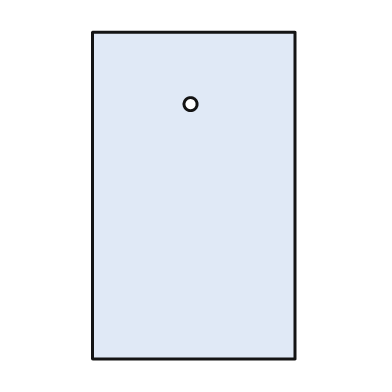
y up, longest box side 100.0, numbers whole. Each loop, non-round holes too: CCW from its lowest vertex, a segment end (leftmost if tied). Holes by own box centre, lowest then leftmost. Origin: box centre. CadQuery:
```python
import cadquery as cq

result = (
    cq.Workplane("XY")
    .moveTo(-31.0, -50.0)
    .lineTo(31.0, -50.0)
    .lineTo(31.0, 50.0)
    .lineTo(-31.0, 50.0)
    .close()
    .moveTo(-1.0, 28.0)
    .circle(2.0)
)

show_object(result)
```